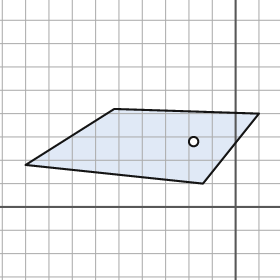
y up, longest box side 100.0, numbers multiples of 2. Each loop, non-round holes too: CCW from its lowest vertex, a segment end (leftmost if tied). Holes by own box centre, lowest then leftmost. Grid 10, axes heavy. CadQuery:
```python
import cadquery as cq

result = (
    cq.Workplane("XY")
    .moveTo(-14.0, 10.0)
    .lineTo(10.0, 40.0)
    .lineTo(-52.0, 42.0)
    .lineTo(-90.0, 18.0)
    .close()
    .moveTo(-18.0, 28.0)
    .circle(2.0)
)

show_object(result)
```